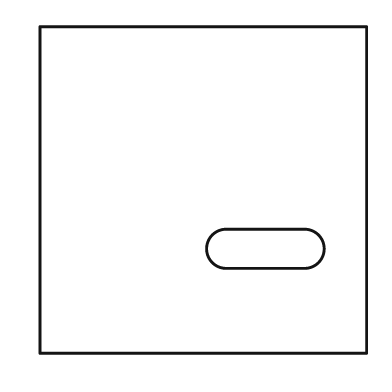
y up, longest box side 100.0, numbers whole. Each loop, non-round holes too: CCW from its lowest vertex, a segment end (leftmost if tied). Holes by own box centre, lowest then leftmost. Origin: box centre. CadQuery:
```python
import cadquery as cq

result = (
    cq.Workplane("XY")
    .moveTo(-50.0, -50.0)
    .lineTo(50.0, -50.0)
    .lineTo(50.0, 50.0)
    .lineTo(-50.0, 50.0)
    .close()
    .moveTo(7.0, -24.0)
    .lineTo(31.0, -24.0)
    .threePointArc((37.0, -18.0), (31.0, -12.0))
    .lineTo(7.0, -12.0)
    .threePointArc((1.0, -18.0), (7.0, -24.0))
    .close()
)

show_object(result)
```